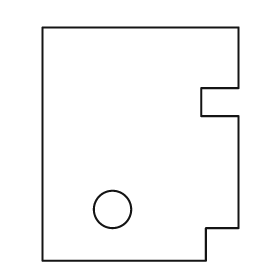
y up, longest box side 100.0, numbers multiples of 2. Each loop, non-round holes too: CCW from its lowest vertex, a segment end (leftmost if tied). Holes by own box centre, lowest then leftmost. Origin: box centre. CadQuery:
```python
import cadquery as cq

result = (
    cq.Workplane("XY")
    .moveTo(-42.0, -50.0)
    .lineTo(28.0, -50.0)
    .lineTo(28.0, -36.0)
    .lineTo(42.0, -36.0)
    .lineTo(42.0, 12.0)
    .lineTo(26.0, 12.0)
    .lineTo(26.0, 24.0)
    .lineTo(42.0, 24.0)
    .lineTo(42.0, 50.0)
    .lineTo(-42.0, 50.0)
    .close()
    .moveTo(-12.0, -28.0)
    .circle(8.0)
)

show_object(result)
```